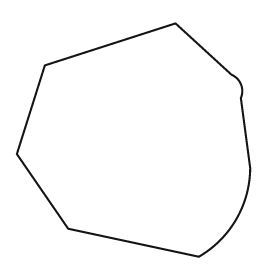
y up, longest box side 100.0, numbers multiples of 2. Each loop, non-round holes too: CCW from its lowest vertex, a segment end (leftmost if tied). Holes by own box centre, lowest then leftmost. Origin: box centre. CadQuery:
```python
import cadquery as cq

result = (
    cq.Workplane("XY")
    .moveTo(28.0, -50.0)
    .threePointArc((44.0, -34.0), (50.0, -12.0))
    .lineTo(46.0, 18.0)
    .threePointArc((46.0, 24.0), (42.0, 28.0))
    .lineTo(18.0, 50.0)
    .lineTo(-38.0, 32.0)
    .lineTo(-50.0, -6.0)
    .lineTo(-28.0, -38.0)
    .close()
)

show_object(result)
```